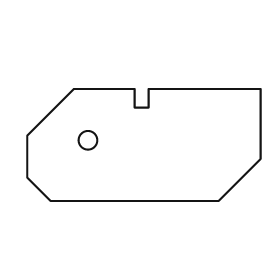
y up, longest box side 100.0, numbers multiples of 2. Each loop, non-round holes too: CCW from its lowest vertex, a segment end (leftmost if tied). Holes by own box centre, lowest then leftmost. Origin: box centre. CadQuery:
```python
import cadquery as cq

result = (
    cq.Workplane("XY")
    .moveTo(-40.0, -24.0)
    .lineTo(32.0, -24.0)
    .lineTo(50.0, -6.0)
    .lineTo(50.0, 24.0)
    .lineTo(2.0, 24.0)
    .lineTo(2.0, 16.0)
    .lineTo(-4.0, 16.0)
    .lineTo(-4.0, 24.0)
    .lineTo(-30.0, 24.0)
    .lineTo(-50.0, 4.0)
    .lineTo(-50.0, -14.0)
    .close()
    .moveTo(-24.0, 2.0)
    .circle(4.0)
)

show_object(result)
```